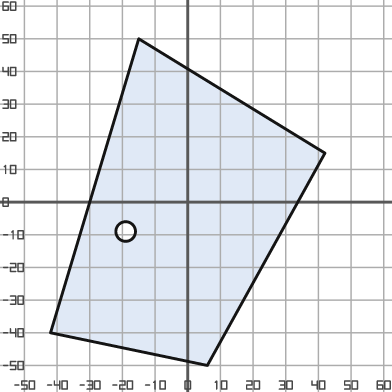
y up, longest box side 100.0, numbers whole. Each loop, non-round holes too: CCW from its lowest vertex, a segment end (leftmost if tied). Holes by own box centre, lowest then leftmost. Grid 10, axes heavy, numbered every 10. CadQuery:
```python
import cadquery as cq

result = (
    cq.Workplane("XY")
    .moveTo(6.0, -50.0)
    .lineTo(42.0, 15.0)
    .lineTo(-15.0, 50.0)
    .lineTo(-42.0, -40.0)
    .close()
    .moveTo(-19.0, -9.0)
    .circle(3.0)
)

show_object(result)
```